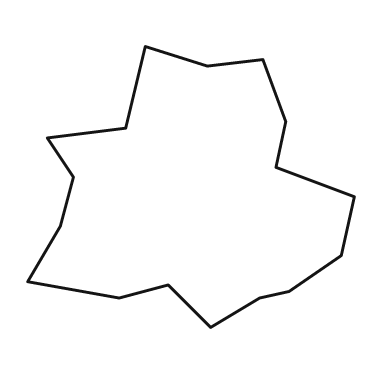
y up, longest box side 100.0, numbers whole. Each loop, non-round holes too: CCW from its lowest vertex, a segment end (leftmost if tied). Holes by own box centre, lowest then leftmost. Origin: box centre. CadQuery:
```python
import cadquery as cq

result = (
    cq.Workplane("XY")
    .moveTo(6.0, -43.0)
    .lineTo(21.0, -34.0)
    .lineTo(30.0, -32.0)
    .lineTo(46.0, -21.0)
    .lineTo(50.0, -3.0)
    .lineTo(26.0, 6.0)
    .lineTo(29.0, 20.0)
    .lineTo(22.0, 39.0)
    .lineTo(5.0, 37.0)
    .lineTo(-14.0, 43.0)
    .lineTo(-20.0, 18.0)
    .lineTo(-44.0, 15.0)
    .lineTo(-36.0, 3.0)
    .lineTo(-40.0, -12.0)
    .lineTo(-50.0, -29.0)
    .lineTo(-22.0, -34.0)
    .lineTo(-7.0, -30.0)
    .close()
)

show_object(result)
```